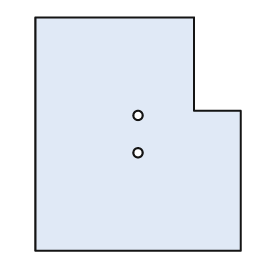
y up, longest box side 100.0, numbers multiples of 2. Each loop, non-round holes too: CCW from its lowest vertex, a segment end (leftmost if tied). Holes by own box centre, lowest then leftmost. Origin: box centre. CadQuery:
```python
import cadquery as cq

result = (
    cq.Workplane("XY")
    .moveTo(-44.0, -50.0)
    .lineTo(44.0, -50.0)
    .lineTo(44.0, 10.0)
    .lineTo(24.0, 10.0)
    .lineTo(24.0, 50.0)
    .lineTo(-44.0, 50.0)
    .close()
    .moveTo(0.0, -8.0)
    .circle(2.0)
    .moveTo(0.0, 8.0)
    .circle(2.0)
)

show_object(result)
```